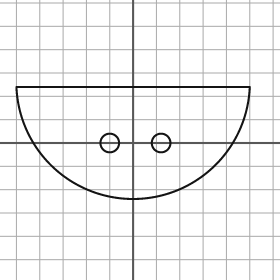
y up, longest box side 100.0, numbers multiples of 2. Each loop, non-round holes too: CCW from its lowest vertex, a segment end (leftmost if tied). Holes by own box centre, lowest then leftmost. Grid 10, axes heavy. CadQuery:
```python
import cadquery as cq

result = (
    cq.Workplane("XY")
    .moveTo(-50.0, 24.0)
    .threePointArc((0.0, -24.0), (50.0, 24.0))
    .close()
    .moveTo(-10.0, 0.0)
    .circle(4.0)
    .moveTo(12.0, 0.0)
    .circle(4.0)
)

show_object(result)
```